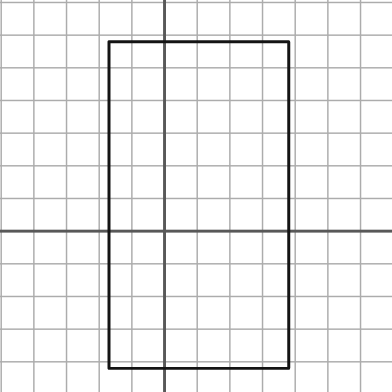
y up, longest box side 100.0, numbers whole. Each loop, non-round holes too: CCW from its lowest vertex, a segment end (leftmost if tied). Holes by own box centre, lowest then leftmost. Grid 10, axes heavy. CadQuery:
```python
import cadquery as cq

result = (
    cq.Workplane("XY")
    .moveTo(-17.0, -42.0)
    .lineTo(38.0, -42.0)
    .lineTo(38.0, 58.0)
    .lineTo(-17.0, 58.0)
    .close()
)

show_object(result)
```